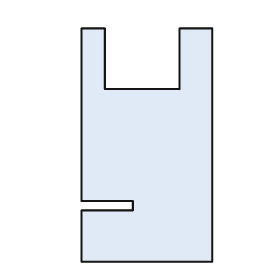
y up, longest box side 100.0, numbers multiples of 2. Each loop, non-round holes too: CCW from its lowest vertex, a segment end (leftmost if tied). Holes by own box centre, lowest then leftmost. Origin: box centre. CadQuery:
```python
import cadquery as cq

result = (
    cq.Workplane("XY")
    .moveTo(-28.0, -50.0)
    .lineTo(28.0, -50.0)
    .lineTo(28.0, 50.0)
    .lineTo(14.0, 50.0)
    .lineTo(14.0, 24.0)
    .lineTo(-18.0, 24.0)
    .lineTo(-18.0, 50.0)
    .lineTo(-28.0, 50.0)
    .lineTo(-28.0, -24.0)
    .lineTo(-6.0, -24.0)
    .lineTo(-6.0, -28.0)
    .lineTo(-28.0, -28.0)
    .close()
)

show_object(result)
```